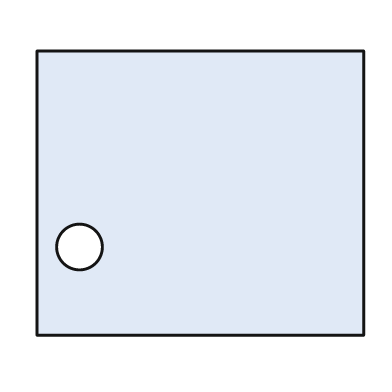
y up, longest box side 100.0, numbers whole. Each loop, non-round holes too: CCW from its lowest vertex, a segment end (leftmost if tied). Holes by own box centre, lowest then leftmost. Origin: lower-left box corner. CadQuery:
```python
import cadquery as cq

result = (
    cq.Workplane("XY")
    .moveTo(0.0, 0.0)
    .lineTo(100.0, 0.0)
    .lineTo(100.0, 87.0)
    .lineTo(0.0, 87.0)
    .close()
    .moveTo(13.0, 27.0)
    .circle(7.0)
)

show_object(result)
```